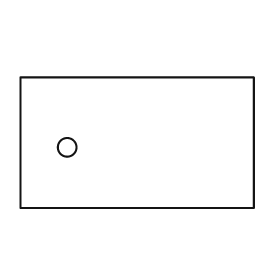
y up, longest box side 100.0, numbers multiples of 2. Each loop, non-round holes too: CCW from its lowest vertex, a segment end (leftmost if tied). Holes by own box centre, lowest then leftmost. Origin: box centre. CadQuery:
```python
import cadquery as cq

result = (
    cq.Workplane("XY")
    .moveTo(-50.0, -28.0)
    .lineTo(50.0, -28.0)
    .lineTo(50.0, 28.0)
    .lineTo(-50.0, 28.0)
    .close()
    .moveTo(-30.0, -2.0)
    .circle(4.0)
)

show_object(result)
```